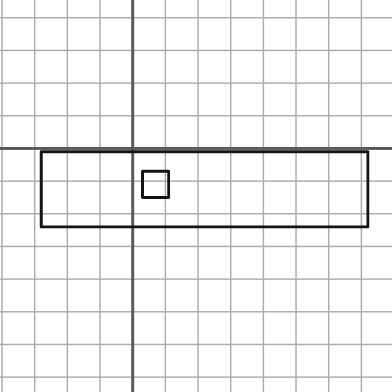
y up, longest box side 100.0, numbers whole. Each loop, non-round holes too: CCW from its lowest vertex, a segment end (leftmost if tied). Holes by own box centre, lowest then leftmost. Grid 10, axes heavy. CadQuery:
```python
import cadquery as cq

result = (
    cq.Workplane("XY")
    .moveTo(-28.0, -24.0)
    .lineTo(72.0, -24.0)
    .lineTo(72.0, -1.0)
    .lineTo(-28.0, -1.0)
    .close()
    .moveTo(3.0, -15.0)
    .lineTo(11.0, -15.0)
    .lineTo(11.0, -7.0)
    .lineTo(3.0, -7.0)
    .close()
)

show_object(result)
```